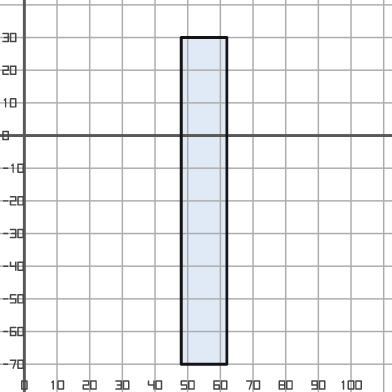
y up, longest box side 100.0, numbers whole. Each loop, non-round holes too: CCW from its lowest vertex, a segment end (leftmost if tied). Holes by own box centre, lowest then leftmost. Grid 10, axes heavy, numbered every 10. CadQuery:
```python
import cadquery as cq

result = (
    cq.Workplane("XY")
    .moveTo(48.0, -70.0)
    .lineTo(62.0, -70.0)
    .lineTo(62.0, 30.0)
    .lineTo(48.0, 30.0)
    .close()
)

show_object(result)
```